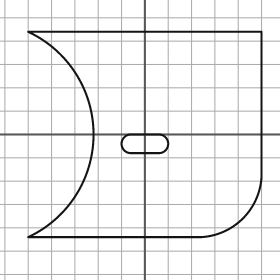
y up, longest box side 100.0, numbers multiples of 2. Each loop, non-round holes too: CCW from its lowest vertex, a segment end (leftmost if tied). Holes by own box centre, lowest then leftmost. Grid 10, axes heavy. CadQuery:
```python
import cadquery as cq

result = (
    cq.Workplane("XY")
    .moveTo(-50.0, -44.0)
    .lineTo(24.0, -44.0)
    .threePointArc((42.0, -36.0), (50.0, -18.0))
    .lineTo(50.0, 44.0)
    .lineTo(-50.0, 44.0)
    .threePointArc((-22.0, 0.0), (-50.0, -44.0))
    .close()
    .moveTo(-6.0, -8.0)
    .lineTo(6.0, -8.0)
    .threePointArc((10.0, -4.0), (6.0, 0.0))
    .lineTo(-6.0, 0.0)
    .threePointArc((-10.0, -4.0), (-6.0, -8.0))
    .close()
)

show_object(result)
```